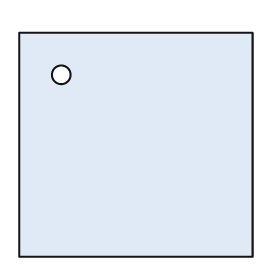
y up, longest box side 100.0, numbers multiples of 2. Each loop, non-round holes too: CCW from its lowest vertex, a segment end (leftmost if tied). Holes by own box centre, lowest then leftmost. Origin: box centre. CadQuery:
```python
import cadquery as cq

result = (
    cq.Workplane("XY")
    .moveTo(-50.0, -48.0)
    .lineTo(50.0, -48.0)
    .lineTo(50.0, 48.0)
    .lineTo(-50.0, 48.0)
    .close()
    .moveTo(-32.0, 30.0)
    .circle(4.0)
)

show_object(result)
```